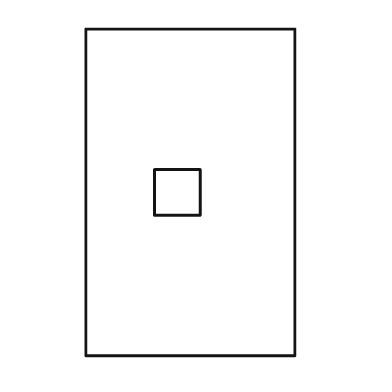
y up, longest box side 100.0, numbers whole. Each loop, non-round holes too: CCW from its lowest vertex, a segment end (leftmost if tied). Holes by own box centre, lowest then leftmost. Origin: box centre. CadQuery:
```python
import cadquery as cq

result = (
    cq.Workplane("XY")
    .moveTo(-32.0, -50.0)
    .lineTo(32.0, -50.0)
    .lineTo(32.0, 50.0)
    .lineTo(-32.0, 50.0)
    .close()
    .moveTo(-11.0, -7.0)
    .lineTo(3.0, -7.0)
    .lineTo(3.0, 7.0)
    .lineTo(-11.0, 7.0)
    .close()
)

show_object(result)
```